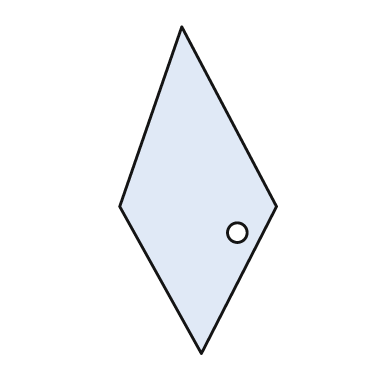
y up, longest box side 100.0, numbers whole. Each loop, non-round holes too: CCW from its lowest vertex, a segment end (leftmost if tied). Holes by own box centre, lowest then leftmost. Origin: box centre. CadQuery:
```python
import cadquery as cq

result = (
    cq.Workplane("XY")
    .moveTo(1.0, -50.0)
    .lineTo(24.0, -5.0)
    .lineTo(-5.0, 50.0)
    .lineTo(-24.0, -5.0)
    .close()
    .moveTo(12.0, -13.0)
    .circle(3.0)
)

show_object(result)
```